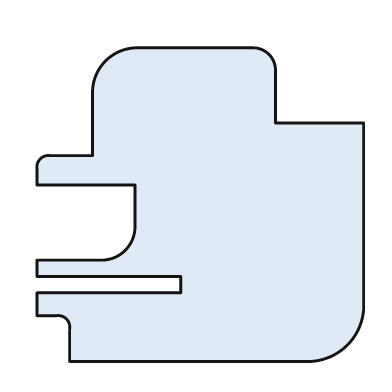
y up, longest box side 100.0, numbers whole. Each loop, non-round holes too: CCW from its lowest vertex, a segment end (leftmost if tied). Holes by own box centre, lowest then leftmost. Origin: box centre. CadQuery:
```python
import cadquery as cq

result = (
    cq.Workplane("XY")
    .moveTo(-40.0, -48.0)
    .lineTo(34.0, -48.0)
    .threePointArc((45.0, -43.0), (50.0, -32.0))
    .lineTo(50.0, 25.0)
    .lineTo(23.0, 25.0)
    .lineTo(23.0, 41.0)
    .threePointArc((21.0, 46.0), (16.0, 48.0))
    .lineTo(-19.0, 48.0)
    .threePointArc((-29.0, 44.0), (-33.0, 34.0))
    .lineTo(-33.0, 15.0)
    .lineTo(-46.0, 15.0)
    .threePointArc((-49.0, 14.0), (-50.0, 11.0))
    .lineTo(-50.0, 6.0)
    .lineTo(-20.0, 6.0)
    .lineTo(-20.0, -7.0)
    .threePointArc((-23.0, -14.0), (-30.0, -17.0))
    .lineTo(-50.0, -17.0)
    .lineTo(-50.0, -22.0)
    .lineTo(-6.0, -22.0)
    .lineTo(-6.0, -27.0)
    .lineTo(-50.0, -27.0)
    .lineTo(-50.0, -34.0)
    .lineTo(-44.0, -34.0)
    .threePointArc((-41.0, -35.0), (-40.0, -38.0))
    .close()
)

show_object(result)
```